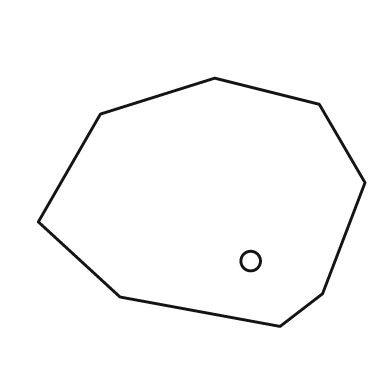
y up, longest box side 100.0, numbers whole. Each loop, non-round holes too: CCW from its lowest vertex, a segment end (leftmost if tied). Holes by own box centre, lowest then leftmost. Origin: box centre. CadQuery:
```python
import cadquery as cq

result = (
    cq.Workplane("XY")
    .moveTo(24.0, -38.0)
    .lineTo(37.0, -28.0)
    .lineTo(50.0, 6.0)
    .lineTo(36.0, 30.0)
    .lineTo(4.0, 38.0)
    .lineTo(-31.0, 27.0)
    .lineTo(-50.0, -6.0)
    .lineTo(-25.0, -29.0)
    .close()
    .moveTo(15.0, -18.0)
    .circle(3.0)
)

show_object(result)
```